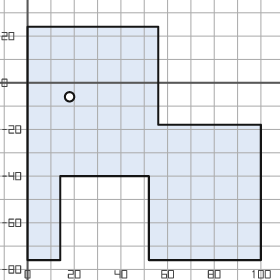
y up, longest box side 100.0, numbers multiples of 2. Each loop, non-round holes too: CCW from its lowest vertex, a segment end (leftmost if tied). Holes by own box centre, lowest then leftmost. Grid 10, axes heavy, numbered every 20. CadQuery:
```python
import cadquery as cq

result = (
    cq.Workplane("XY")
    .moveTo(0.0, -76.0)
    .lineTo(14.0, -76.0)
    .lineTo(14.0, -40.0)
    .lineTo(52.0, -40.0)
    .lineTo(52.0, -76.0)
    .lineTo(100.0, -76.0)
    .lineTo(100.0, -18.0)
    .lineTo(56.0, -18.0)
    .lineTo(56.0, 24.0)
    .lineTo(0.0, 24.0)
    .close()
    .moveTo(18.0, -6.0)
    .circle(2.0)
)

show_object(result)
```